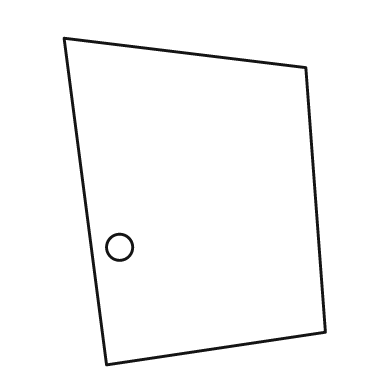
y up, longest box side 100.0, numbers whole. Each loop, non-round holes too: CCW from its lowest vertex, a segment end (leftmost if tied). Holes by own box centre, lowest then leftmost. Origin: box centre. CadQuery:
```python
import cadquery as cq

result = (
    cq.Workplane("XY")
    .moveTo(-27.0, -50.0)
    .lineTo(40.0, -40.0)
    .lineTo(34.0, 41.0)
    .lineTo(-40.0, 50.0)
    .close()
    .moveTo(-23.0, -14.0)
    .circle(4.0)
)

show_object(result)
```